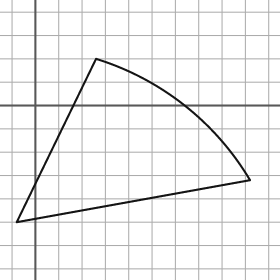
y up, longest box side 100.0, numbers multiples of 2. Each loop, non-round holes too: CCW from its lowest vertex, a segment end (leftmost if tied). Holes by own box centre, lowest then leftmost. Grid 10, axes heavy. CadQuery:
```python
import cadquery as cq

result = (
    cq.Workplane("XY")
    .moveTo(-8.0, -50.0)
    .lineTo(92.0, -32.0)
    .threePointArc((64.0, 0.0), (26.0, 20.0))
    .close()
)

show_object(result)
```